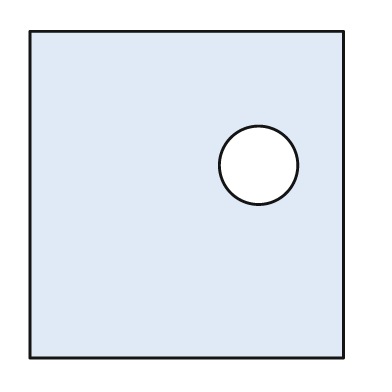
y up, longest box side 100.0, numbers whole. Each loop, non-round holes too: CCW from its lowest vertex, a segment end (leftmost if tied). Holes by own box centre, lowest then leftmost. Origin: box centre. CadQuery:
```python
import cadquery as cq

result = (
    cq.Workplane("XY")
    .moveTo(-48.0, -50.0)
    .lineTo(48.0, -50.0)
    .lineTo(48.0, 50.0)
    .lineTo(-48.0, 50.0)
    .close()
    .moveTo(22.0, 9.0)
    .circle(12.0)
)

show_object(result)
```